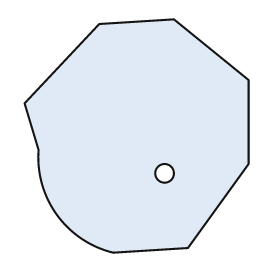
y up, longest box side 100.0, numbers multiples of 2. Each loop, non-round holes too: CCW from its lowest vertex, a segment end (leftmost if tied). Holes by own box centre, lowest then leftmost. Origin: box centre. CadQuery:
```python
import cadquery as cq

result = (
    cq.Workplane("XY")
    .moveTo(-10.0, -50.0)
    .lineTo(22.0, -48.0)
    .lineTo(48.0, -12.0)
    .lineTo(48.0, 24.0)
    .lineTo(16.0, 50.0)
    .lineTo(-16.0, 48.0)
    .lineTo(-48.0, 14.0)
    .lineTo(-42.0, -6.0)
    .threePointArc((-34.0, -34.0), (-10.0, -50.0))
    .close()
    .moveTo(12.0, -16.0)
    .circle(4.0)
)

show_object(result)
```